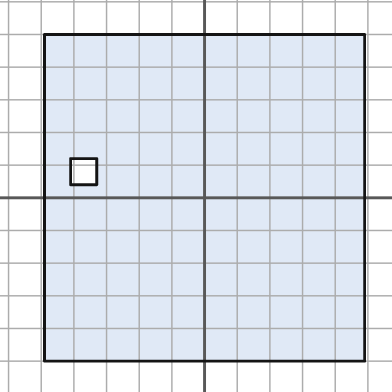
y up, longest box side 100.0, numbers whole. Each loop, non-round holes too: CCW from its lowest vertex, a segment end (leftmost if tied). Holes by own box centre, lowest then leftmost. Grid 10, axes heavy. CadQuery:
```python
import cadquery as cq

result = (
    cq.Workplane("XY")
    .moveTo(-49.0, -50.0)
    .lineTo(49.0, -50.0)
    .lineTo(49.0, 50.0)
    .lineTo(-49.0, 50.0)
    .close()
    .moveTo(-41.0, 4.0)
    .lineTo(-33.0, 4.0)
    .lineTo(-33.0, 12.0)
    .lineTo(-41.0, 12.0)
    .close()
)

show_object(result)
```